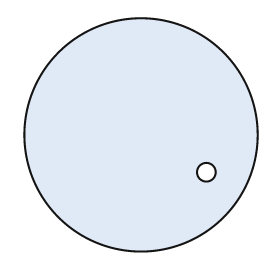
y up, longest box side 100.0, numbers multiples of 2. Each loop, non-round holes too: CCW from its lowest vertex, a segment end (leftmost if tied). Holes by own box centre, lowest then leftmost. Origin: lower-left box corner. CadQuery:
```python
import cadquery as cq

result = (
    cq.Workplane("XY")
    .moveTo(50.0, 50.0)
    .circle(50.0)
    .moveTo(78.0, 34.0)
    .circle(4.0)
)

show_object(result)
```